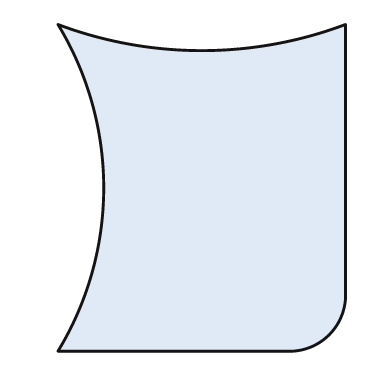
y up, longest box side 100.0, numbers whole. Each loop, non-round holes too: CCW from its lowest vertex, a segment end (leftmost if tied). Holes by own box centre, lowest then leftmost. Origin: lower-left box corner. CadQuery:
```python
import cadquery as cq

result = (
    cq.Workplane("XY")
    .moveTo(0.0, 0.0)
    .lineTo(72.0, 0.0)
    .threePointArc((83.0, 5.0), (88.0, 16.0))
    .lineTo(88.0, 100.0)
    .threePointArc((44.0, 92.0), (0.0, 100.0))
    .threePointArc((14.0, 50.0), (0.0, 0.0))
    .close()
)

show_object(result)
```